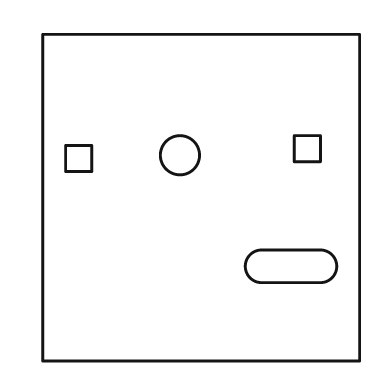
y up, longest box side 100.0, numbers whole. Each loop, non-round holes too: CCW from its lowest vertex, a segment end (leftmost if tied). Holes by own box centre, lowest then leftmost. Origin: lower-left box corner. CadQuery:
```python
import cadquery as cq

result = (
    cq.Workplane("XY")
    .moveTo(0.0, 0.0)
    .lineTo(97.0, 0.0)
    .lineTo(97.0, 100.0)
    .lineTo(0.0, 100.0)
    .close()
    .moveTo(67.0, 24.0)
    .lineTo(85.0, 24.0)
    .threePointArc((90.0, 29.0), (85.0, 34.0))
    .lineTo(67.0, 34.0)
    .threePointArc((62.0, 29.0), (67.0, 24.0))
    .close()
    .moveTo(7.0, 58.0)
    .lineTo(15.0, 58.0)
    .lineTo(15.0, 66.0)
    .lineTo(7.0, 66.0)
    .close()
    .moveTo(42.0, 63.0)
    .circle(6.0)
    .moveTo(77.0, 61.0)
    .lineTo(85.0, 61.0)
    .lineTo(85.0, 69.0)
    .lineTo(77.0, 69.0)
    .close()
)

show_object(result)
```